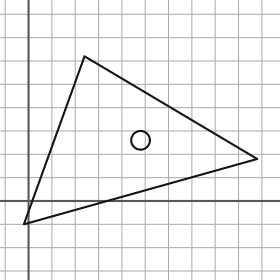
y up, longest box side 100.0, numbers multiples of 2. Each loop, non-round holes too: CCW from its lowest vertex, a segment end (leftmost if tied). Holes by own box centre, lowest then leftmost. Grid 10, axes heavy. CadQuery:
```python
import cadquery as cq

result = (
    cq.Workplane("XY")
    .moveTo(-2.0, -10.0)
    .lineTo(98.0, 18.0)
    .lineTo(24.0, 62.0)
    .close()
    .moveTo(48.0, 26.0)
    .circle(4.0)
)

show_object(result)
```